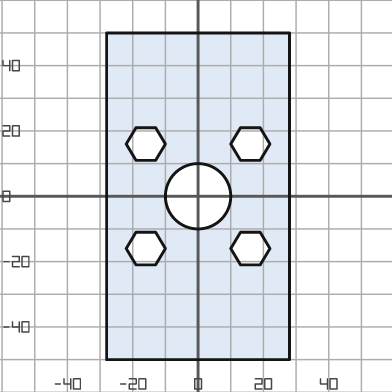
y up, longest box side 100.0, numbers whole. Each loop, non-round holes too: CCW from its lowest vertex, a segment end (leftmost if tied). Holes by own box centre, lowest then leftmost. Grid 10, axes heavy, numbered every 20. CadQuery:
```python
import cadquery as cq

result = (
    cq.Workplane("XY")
    .moveTo(-28.0, -50.0)
    .lineTo(28.0, -50.0)
    .lineTo(28.0, 50.0)
    .lineTo(-28.0, 50.0)
    .close()
    .moveTo(-19.0, -21.0)
    .lineTo(-13.0, -21.0)
    .lineTo(-10.0, -16.0)
    .lineTo(-13.0, -11.0)
    .lineTo(-19.0, -11.0)
    .lineTo(-22.0, -16.0)
    .close()
    .moveTo(13.0, -21.0)
    .lineTo(19.0, -21.0)
    .lineTo(22.0, -16.0)
    .lineTo(19.0, -11.0)
    .lineTo(13.0, -11.0)
    .lineTo(10.0, -16.0)
    .close()
    .moveTo(0.0, 0.0)
    .circle(10.0)
    .moveTo(-19.0, 11.0)
    .lineTo(-13.0, 11.0)
    .lineTo(-10.0, 16.0)
    .lineTo(-13.0, 21.0)
    .lineTo(-19.0, 21.0)
    .lineTo(-22.0, 16.0)
    .close()
    .moveTo(13.0, 11.0)
    .lineTo(19.0, 11.0)
    .lineTo(22.0, 16.0)
    .lineTo(19.0, 21.0)
    .lineTo(13.0, 21.0)
    .lineTo(10.0, 16.0)
    .close()
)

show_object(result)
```